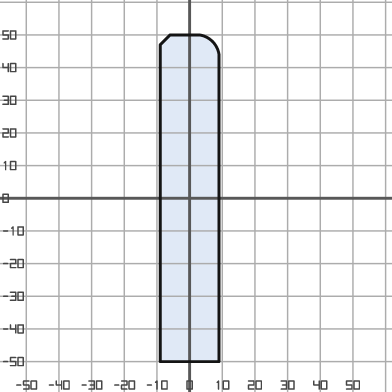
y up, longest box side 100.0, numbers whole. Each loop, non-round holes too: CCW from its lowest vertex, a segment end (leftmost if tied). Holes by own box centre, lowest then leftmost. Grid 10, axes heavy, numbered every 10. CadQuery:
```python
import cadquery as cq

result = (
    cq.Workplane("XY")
    .moveTo(-9.0, -50.0)
    .lineTo(9.0, -50.0)
    .lineTo(9.0, 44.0)
    .threePointArc((7.0, 48.0), (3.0, 50.0))
    .lineTo(-6.0, 50.0)
    .lineTo(-9.0, 47.0)
    .close()
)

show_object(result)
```